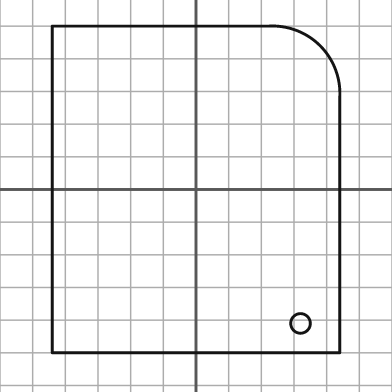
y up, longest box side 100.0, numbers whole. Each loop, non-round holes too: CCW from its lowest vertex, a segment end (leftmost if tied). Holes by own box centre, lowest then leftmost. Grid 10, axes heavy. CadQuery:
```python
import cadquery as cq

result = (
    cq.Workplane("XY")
    .moveTo(-44.0, -50.0)
    .lineTo(44.0, -50.0)
    .lineTo(44.0, 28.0)
    .threePointArc((38.0, 44.0), (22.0, 50.0))
    .lineTo(-44.0, 50.0)
    .close()
    .moveTo(32.0, -41.0)
    .circle(3.0)
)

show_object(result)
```